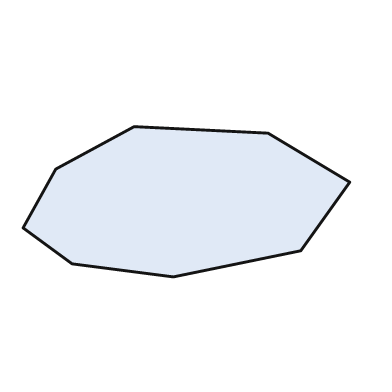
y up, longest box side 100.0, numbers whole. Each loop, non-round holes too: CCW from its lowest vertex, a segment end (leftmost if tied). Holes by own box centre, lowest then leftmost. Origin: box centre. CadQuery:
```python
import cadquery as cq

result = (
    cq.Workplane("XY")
    .moveTo(-4.0, -23.0)
    .lineTo(35.0, -15.0)
    .lineTo(50.0, 6.0)
    .lineTo(25.0, 21.0)
    .lineTo(-16.0, 23.0)
    .lineTo(-40.0, 10.0)
    .lineTo(-50.0, -8.0)
    .lineTo(-35.0, -19.0)
    .close()
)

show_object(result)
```